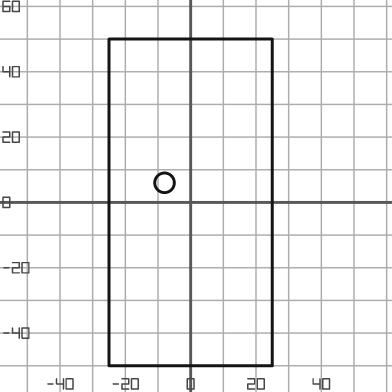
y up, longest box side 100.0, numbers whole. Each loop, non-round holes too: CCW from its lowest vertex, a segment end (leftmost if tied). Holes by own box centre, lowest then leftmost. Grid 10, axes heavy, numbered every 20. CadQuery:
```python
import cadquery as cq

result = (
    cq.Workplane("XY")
    .moveTo(-25.0, -50.0)
    .lineTo(25.0, -50.0)
    .lineTo(25.0, 50.0)
    .lineTo(-25.0, 50.0)
    .close()
    .moveTo(-8.0, 6.0)
    .circle(3.0)
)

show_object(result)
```